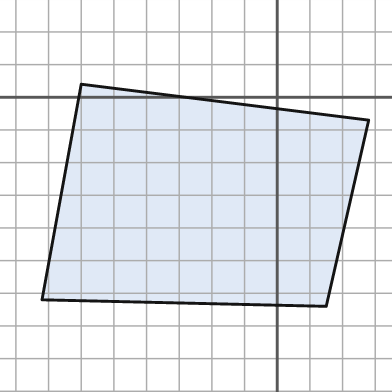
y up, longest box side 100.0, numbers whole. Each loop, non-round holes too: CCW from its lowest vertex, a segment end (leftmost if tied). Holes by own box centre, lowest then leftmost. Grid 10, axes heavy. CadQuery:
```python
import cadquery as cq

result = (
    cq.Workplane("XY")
    .moveTo(15.0, -64.0)
    .lineTo(28.0, -7.0)
    .lineTo(-60.0, 4.0)
    .lineTo(-72.0, -62.0)
    .close()
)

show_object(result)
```